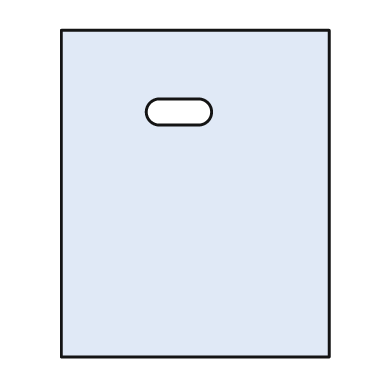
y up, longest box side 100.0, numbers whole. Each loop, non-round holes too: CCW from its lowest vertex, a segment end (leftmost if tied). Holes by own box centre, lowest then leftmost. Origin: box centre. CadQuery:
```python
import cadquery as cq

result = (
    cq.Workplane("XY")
    .moveTo(-41.0, -50.0)
    .lineTo(41.0, -50.0)
    .lineTo(41.0, 50.0)
    .lineTo(-41.0, 50.0)
    .close()
    .moveTo(-11.0, 21.0)
    .lineTo(1.0, 21.0)
    .threePointArc((5.0, 25.0), (1.0, 29.0))
    .lineTo(-11.0, 29.0)
    .threePointArc((-15.0, 25.0), (-11.0, 21.0))
    .close()
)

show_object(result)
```